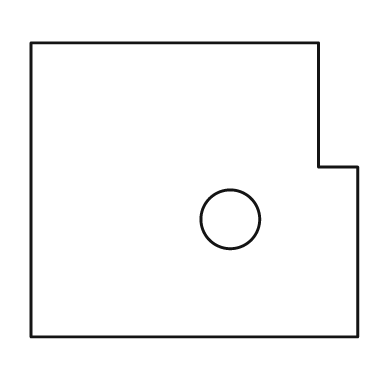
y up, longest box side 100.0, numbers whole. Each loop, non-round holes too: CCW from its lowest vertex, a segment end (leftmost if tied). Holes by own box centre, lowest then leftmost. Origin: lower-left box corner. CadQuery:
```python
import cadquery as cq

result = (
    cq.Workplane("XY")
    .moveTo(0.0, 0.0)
    .lineTo(100.0, 0.0)
    .lineTo(100.0, 52.0)
    .lineTo(88.0, 52.0)
    .lineTo(88.0, 90.0)
    .lineTo(0.0, 90.0)
    .close()
    .moveTo(61.0, 36.0)
    .circle(9.0)
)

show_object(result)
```